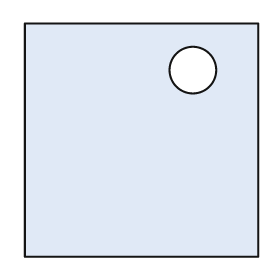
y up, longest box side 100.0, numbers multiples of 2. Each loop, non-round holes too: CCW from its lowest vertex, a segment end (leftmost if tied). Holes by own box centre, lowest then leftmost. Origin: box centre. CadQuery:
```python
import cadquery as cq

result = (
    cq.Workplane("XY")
    .moveTo(-50.0, -50.0)
    .lineTo(50.0, -50.0)
    .lineTo(50.0, 50.0)
    .lineTo(-50.0, 50.0)
    .close()
    .moveTo(22.0, 30.0)
    .circle(10.0)
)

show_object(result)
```